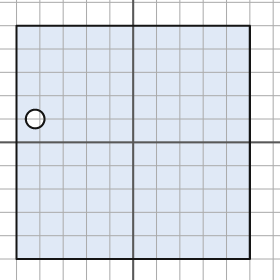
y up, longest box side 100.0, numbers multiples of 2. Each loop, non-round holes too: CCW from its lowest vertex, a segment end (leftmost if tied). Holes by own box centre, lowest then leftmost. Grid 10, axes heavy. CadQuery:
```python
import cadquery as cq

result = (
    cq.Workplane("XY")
    .moveTo(-50.0, -50.0)
    .lineTo(50.0, -50.0)
    .lineTo(50.0, 50.0)
    .lineTo(-50.0, 50.0)
    .close()
    .moveTo(-42.0, 10.0)
    .circle(4.0)
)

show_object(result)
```